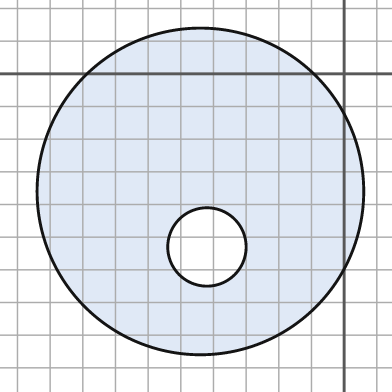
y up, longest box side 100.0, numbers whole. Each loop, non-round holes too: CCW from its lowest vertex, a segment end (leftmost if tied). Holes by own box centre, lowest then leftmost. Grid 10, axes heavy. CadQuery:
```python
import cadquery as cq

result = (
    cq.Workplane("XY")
    .moveTo(-44.0, -36.0)
    .circle(50.0)
    .moveTo(-42.0, -53.0)
    .circle(12.0)
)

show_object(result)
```